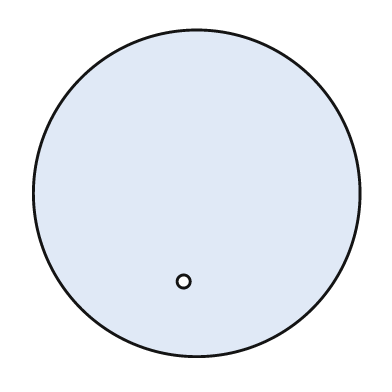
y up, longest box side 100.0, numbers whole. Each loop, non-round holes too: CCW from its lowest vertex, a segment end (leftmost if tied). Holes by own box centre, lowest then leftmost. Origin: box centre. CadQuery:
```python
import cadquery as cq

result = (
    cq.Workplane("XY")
    .moveTo(0.0, 0.0)
    .circle(50.0)
    .moveTo(-4.0, -27.0)
    .circle(2.0)
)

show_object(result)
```